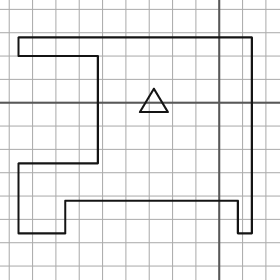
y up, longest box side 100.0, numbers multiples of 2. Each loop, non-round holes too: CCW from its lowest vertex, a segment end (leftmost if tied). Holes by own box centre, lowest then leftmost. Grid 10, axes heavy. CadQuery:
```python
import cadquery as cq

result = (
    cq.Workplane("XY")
    .moveTo(-86.0, -56.0)
    .lineTo(-66.0, -56.0)
    .lineTo(-66.0, -42.0)
    .lineTo(8.0, -42.0)
    .lineTo(8.0, -56.0)
    .lineTo(14.0, -56.0)
    .lineTo(14.0, 28.0)
    .lineTo(-86.0, 28.0)
    .lineTo(-86.0, 20.0)
    .lineTo(-52.0, 20.0)
    .lineTo(-52.0, -26.0)
    .lineTo(-86.0, -26.0)
    .close()
    .moveTo(-34.0, -4.0)
    .lineTo(-22.0, -4.0)
    .lineTo(-28.0, 6.0)
    .close()
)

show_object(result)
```